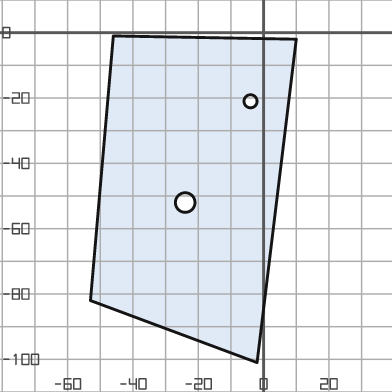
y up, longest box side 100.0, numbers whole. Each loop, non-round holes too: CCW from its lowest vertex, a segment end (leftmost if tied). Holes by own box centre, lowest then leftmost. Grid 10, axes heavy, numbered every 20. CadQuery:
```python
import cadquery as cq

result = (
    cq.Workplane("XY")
    .moveTo(-2.0, -101.0)
    .lineTo(10.0, -2.0)
    .lineTo(-46.0, -1.0)
    .lineTo(-53.0, -82.0)
    .close()
    .moveTo(-24.0, -52.0)
    .circle(3.0)
    .moveTo(-4.0, -21.0)
    .circle(2.0)
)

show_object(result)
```